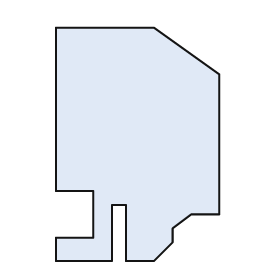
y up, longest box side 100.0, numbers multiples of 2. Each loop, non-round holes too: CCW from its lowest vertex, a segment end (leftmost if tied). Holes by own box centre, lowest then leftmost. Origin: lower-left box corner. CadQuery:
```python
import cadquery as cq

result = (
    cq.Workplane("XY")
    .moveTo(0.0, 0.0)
    .lineTo(24.0, 0.0)
    .lineTo(24.0, 24.0)
    .lineTo(30.0, 24.0)
    .lineTo(30.0, 0.0)
    .lineTo(42.0, 0.0)
    .lineTo(50.0, 8.0)
    .lineTo(50.0, 14.0)
    .lineTo(58.0, 20.0)
    .lineTo(70.0, 20.0)
    .lineTo(70.0, 80.0)
    .lineTo(42.0, 100.0)
    .lineTo(0.0, 100.0)
    .lineTo(0.0, 30.0)
    .lineTo(16.0, 30.0)
    .lineTo(16.0, 10.0)
    .lineTo(0.0, 10.0)
    .close()
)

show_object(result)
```